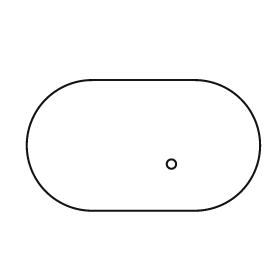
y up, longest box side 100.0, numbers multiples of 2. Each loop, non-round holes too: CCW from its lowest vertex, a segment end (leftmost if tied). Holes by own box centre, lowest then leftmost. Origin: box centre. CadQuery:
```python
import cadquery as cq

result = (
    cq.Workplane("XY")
    .moveTo(-22.0, -28.0)
    .lineTo(22.0, -28.0)
    .threePointArc((50.0, 0.0), (22.0, 28.0))
    .lineTo(-22.0, 28.0)
    .threePointArc((-50.0, 0.0), (-22.0, -28.0))
    .close()
    .moveTo(12.0, -8.0)
    .circle(2.0)
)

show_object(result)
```